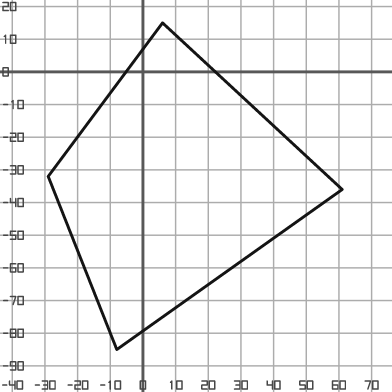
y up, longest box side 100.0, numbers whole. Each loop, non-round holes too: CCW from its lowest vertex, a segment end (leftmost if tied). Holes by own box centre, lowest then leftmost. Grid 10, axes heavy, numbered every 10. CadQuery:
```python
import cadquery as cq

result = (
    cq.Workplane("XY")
    .moveTo(-8.0, -85.0)
    .lineTo(61.0, -36.0)
    .lineTo(6.0, 15.0)
    .lineTo(-29.0, -32.0)
    .close()
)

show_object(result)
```